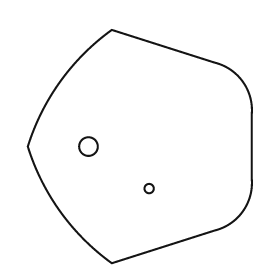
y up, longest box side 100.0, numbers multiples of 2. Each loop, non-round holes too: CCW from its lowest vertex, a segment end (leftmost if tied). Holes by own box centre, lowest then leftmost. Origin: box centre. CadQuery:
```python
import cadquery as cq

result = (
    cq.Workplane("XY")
    .moveTo(-12.0, -50.0)
    .lineTo(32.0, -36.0)
    .threePointArc((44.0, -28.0), (48.0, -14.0))
    .lineTo(48.0, 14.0)
    .threePointArc((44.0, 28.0), (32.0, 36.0))
    .lineTo(-12.0, 50.0)
    .threePointArc((-34.0, 28.0), (-48.0, 0.0))
    .threePointArc((-34.0, -28.0), (-12.0, -50.0))
    .close()
    .moveTo(4.0, -18.0)
    .circle(2.0)
    .moveTo(-22.0, 0.0)
    .circle(4.0)
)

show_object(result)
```